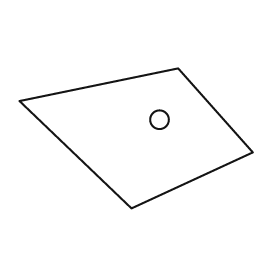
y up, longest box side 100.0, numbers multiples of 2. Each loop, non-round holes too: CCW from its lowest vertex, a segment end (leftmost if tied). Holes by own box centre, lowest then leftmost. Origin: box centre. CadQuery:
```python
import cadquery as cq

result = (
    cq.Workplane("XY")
    .moveTo(-2.0, -30.0)
    .lineTo(50.0, -6.0)
    .lineTo(18.0, 30.0)
    .lineTo(-50.0, 16.0)
    .close()
    .moveTo(10.0, 8.0)
    .circle(4.0)
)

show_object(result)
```